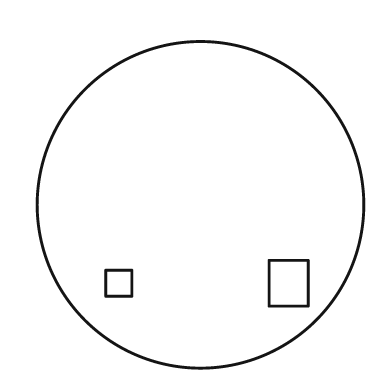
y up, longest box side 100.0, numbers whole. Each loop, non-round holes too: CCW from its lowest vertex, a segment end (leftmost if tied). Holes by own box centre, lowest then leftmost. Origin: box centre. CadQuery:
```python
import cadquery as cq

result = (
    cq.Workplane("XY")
    .moveTo(0.0, 0.0)
    .circle(50.0)
    .moveTo(-29.0, -28.0)
    .lineTo(-21.0, -28.0)
    .lineTo(-21.0, -20.0)
    .lineTo(-29.0, -20.0)
    .close()
    .moveTo(21.0, -31.0)
    .lineTo(33.0, -31.0)
    .lineTo(33.0, -17.0)
    .lineTo(21.0, -17.0)
    .close()
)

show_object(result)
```